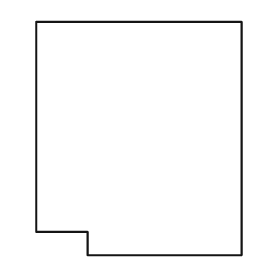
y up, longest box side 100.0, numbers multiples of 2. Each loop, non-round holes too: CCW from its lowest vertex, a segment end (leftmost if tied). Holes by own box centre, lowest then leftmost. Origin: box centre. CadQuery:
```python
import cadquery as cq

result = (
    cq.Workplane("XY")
    .moveTo(-22.0, -50.0)
    .lineTo(44.0, -50.0)
    .lineTo(44.0, 50.0)
    .lineTo(-44.0, 50.0)
    .lineTo(-44.0, -40.0)
    .lineTo(-22.0, -40.0)
    .close()
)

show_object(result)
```